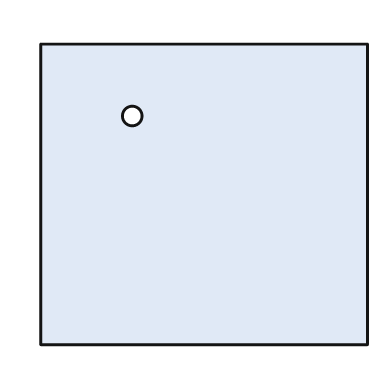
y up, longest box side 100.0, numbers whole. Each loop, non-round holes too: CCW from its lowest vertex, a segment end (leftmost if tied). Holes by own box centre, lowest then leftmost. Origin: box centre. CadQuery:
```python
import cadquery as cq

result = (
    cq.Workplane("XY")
    .moveTo(-50.0, -46.0)
    .lineTo(50.0, -46.0)
    .lineTo(50.0, 46.0)
    .lineTo(-50.0, 46.0)
    .close()
    .moveTo(-22.0, 24.0)
    .circle(3.0)
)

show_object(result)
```